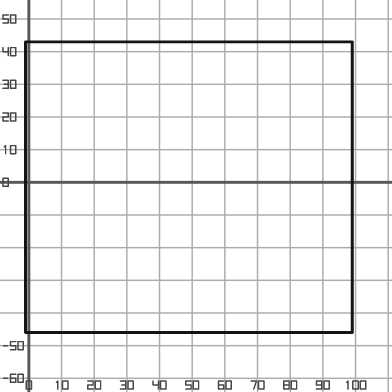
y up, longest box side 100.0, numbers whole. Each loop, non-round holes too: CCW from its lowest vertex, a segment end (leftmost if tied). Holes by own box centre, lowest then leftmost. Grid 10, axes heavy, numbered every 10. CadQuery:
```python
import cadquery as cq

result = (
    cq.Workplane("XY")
    .moveTo(-1.0, -46.0)
    .lineTo(99.0, -46.0)
    .lineTo(99.0, 43.0)
    .lineTo(-1.0, 43.0)
    .close()
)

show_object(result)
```